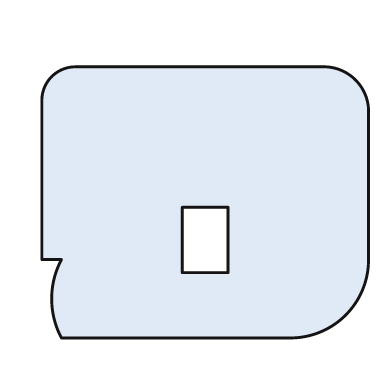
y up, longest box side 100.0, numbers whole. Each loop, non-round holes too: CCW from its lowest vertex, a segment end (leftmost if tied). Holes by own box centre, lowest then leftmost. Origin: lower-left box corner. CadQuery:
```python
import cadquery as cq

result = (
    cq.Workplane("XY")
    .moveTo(6.0, 0.0)
    .lineTo(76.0, 0.0)
    .threePointArc((93.0, 7.0), (100.0, 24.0))
    .lineTo(100.0, 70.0)
    .threePointArc((96.0, 79.0), (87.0, 83.0))
    .lineTo(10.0, 83.0)
    .threePointArc((3.0, 80.0), (0.0, 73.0))
    .lineTo(0.0, 24.0)
    .lineTo(6.0, 24.0)
    .threePointArc((3.0, 12.0), (6.0, 0.0))
    .close()
    .moveTo(43.0, 20.0)
    .lineTo(57.0, 20.0)
    .lineTo(57.0, 40.0)
    .lineTo(43.0, 40.0)
    .close()
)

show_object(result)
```